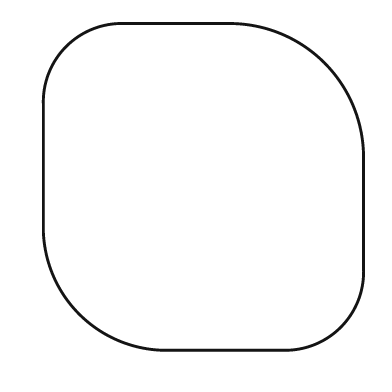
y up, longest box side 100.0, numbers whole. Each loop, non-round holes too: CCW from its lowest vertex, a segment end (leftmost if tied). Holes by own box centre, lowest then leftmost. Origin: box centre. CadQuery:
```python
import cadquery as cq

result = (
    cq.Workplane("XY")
    .moveTo(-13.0, -50.0)
    .lineTo(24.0, -50.0)
    .threePointArc((42.0, -43.0), (49.0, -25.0))
    .lineTo(49.0, 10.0)
    .threePointArc((37.0, 38.0), (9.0, 50.0))
    .lineTo(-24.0, 50.0)
    .threePointArc((-42.0, 43.0), (-49.0, 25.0))
    .lineTo(-49.0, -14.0)
    .threePointArc((-38.0, -39.0), (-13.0, -50.0))
    .close()
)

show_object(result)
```